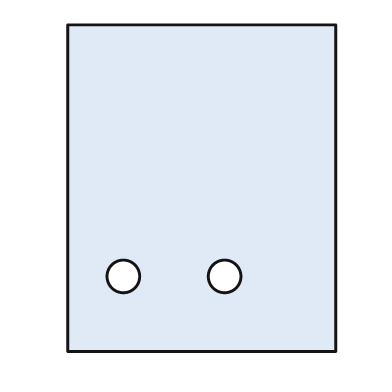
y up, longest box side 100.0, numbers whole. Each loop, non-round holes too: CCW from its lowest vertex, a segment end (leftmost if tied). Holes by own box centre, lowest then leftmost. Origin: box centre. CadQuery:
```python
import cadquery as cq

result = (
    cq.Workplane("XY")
    .moveTo(-41.0, -50.0)
    .lineTo(41.0, -50.0)
    .lineTo(41.0, 50.0)
    .lineTo(-41.0, 50.0)
    .close()
    .moveTo(-24.0, -27.0)
    .circle(5.0)
    .moveTo(7.0, -27.0)
    .circle(5.0)
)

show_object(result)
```